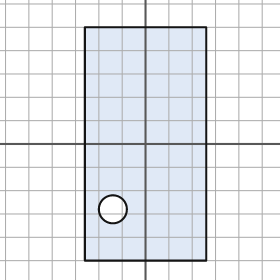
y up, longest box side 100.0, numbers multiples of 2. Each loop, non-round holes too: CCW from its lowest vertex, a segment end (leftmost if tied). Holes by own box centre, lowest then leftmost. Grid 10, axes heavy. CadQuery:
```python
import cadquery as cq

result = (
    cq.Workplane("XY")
    .moveTo(-26.0, -50.0)
    .lineTo(26.0, -50.0)
    .lineTo(26.0, 50.0)
    .lineTo(-26.0, 50.0)
    .close()
    .moveTo(-14.0, -28.0)
    .circle(6.0)
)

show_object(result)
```